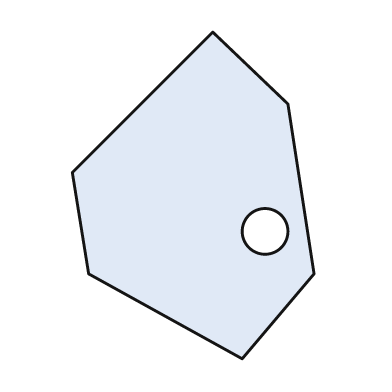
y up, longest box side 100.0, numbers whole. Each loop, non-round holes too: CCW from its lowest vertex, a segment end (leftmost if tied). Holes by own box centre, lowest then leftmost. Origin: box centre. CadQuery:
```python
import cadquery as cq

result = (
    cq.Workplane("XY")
    .moveTo(15.0, -50.0)
    .lineTo(37.0, -24.0)
    .lineTo(29.0, 28.0)
    .lineTo(6.0, 50.0)
    .lineTo(-37.0, 7.0)
    .lineTo(-32.0, -24.0)
    .close()
    .moveTo(22.0, -11.0)
    .circle(7.0)
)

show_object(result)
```